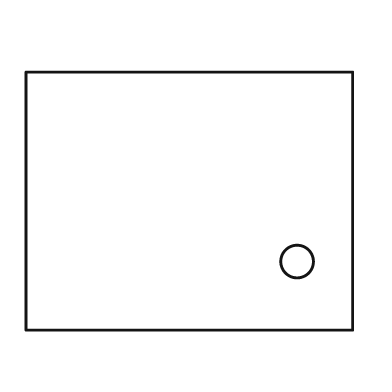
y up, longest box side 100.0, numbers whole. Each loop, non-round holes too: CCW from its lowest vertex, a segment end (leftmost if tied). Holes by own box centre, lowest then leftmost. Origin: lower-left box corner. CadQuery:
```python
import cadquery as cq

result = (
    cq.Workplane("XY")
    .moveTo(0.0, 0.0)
    .lineTo(100.0, 0.0)
    .lineTo(100.0, 79.0)
    .lineTo(0.0, 79.0)
    .close()
    .moveTo(83.0, 21.0)
    .circle(5.0)
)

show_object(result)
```